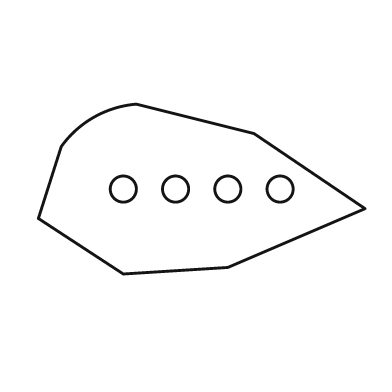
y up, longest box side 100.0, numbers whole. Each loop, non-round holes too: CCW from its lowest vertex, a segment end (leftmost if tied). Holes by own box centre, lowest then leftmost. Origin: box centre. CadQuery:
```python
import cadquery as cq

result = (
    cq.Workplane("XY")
    .moveTo(-24.0, -26.0)
    .lineTo(8.0, -24.0)
    .lineTo(50.0, -6.0)
    .lineTo(16.0, 17.0)
    .lineTo(-20.0, 26.0)
    .threePointArc((-33.0, 22.0), (-43.0, 13.0))
    .lineTo(-50.0, -9.0)
    .close()
    .moveTo(-24.0, 0.0)
    .circle(4.0)
    .moveTo(-8.0, 0.0)
    .circle(4.0)
    .moveTo(8.0, 0.0)
    .circle(4.0)
    .moveTo(24.0, 0.0)
    .circle(4.0)
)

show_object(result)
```